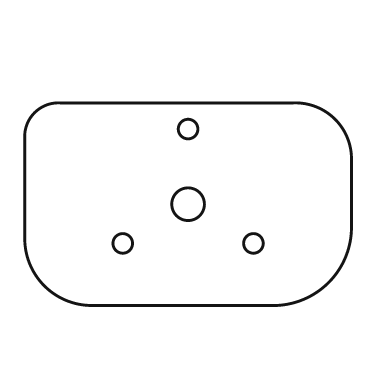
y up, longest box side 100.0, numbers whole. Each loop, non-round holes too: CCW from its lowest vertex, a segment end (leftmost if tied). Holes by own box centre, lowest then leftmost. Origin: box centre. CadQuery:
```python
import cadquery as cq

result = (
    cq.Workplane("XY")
    .moveTo(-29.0, -31.0)
    .lineTo(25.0, -31.0)
    .threePointArc((43.0, -24.0), (50.0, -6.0))
    .lineTo(50.0, 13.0)
    .threePointArc((45.0, 26.0), (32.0, 31.0))
    .lineTo(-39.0, 31.0)
    .threePointArc((-47.0, 28.0), (-50.0, 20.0))
    .lineTo(-50.0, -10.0)
    .threePointArc((-44.0, -25.0), (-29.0, -31.0))
    .close()
    .moveTo(-20.0, -12.0)
    .circle(3.0)
    .moveTo(20.0, -12.0)
    .circle(3.0)
    .moveTo(0.0, 0.0)
    .circle(5.0)
    .moveTo(0.0, 23.0)
    .circle(3.0)
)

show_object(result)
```